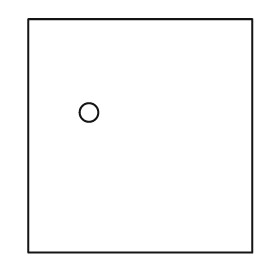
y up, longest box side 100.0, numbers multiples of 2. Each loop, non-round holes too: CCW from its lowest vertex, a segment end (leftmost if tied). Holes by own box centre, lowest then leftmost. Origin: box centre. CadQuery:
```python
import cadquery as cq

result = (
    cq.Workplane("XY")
    .moveTo(-48.0, -50.0)
    .lineTo(48.0, -50.0)
    .lineTo(48.0, 50.0)
    .lineTo(-48.0, 50.0)
    .close()
    .moveTo(-22.0, 10.0)
    .circle(4.0)
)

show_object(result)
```